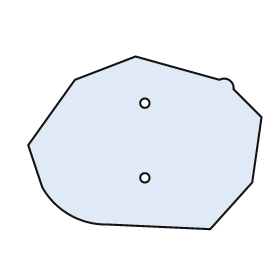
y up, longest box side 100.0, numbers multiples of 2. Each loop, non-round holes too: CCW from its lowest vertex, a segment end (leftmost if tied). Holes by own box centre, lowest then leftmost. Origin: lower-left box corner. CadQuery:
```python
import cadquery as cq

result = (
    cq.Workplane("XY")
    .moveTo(78.0, 0.0)
    .lineTo(96.0, 20.0)
    .lineTo(100.0, 48.0)
    .lineTo(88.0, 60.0)
    .threePointArc((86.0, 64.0), (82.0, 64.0))
    .lineTo(46.0, 74.0)
    .lineTo(20.0, 64.0)
    .lineTo(0.0, 36.0)
    .lineTo(6.0, 18.0)
    .threePointArc((18.0, 6.0), (34.0, 2.0))
    .close()
    .moveTo(50.0, 22.0)
    .circle(2.0)
    .moveTo(50.0, 54.0)
    .circle(2.0)
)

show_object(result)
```